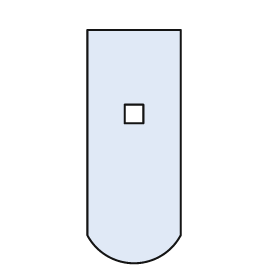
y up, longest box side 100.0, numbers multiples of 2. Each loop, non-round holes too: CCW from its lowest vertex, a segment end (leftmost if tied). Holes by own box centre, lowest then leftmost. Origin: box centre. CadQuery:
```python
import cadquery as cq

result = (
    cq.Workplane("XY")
    .moveTo(-20.0, -38.0)
    .threePointArc((0.0, -50.0), (20.0, -38.0))
    .lineTo(20.0, 50.0)
    .lineTo(-20.0, 50.0)
    .close()
    .moveTo(-4.0, 10.0)
    .lineTo(4.0, 10.0)
    .lineTo(4.0, 18.0)
    .lineTo(-4.0, 18.0)
    .close()
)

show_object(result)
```